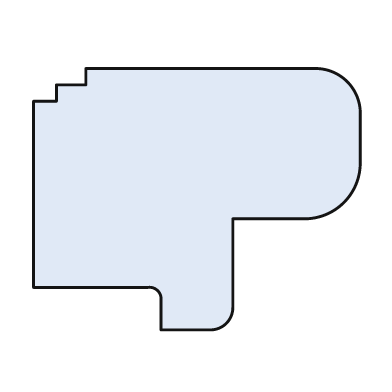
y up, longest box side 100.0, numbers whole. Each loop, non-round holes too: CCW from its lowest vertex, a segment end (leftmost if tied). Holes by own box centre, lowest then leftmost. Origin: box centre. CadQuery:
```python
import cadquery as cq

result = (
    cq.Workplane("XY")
    .moveTo(-11.0, -40.0)
    .lineTo(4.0, -40.0)
    .threePointArc((9.0, -38.0), (11.0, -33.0))
    .lineTo(11.0, -6.0)
    .lineTo(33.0, -6.0)
    .threePointArc((45.0, -1.0), (50.0, 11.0))
    .lineTo(50.0, 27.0)
    .threePointArc((46.0, 36.0), (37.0, 40.0))
    .lineTo(-34.0, 40.0)
    .lineTo(-34.0, 35.0)
    .lineTo(-43.0, 35.0)
    .lineTo(-43.0, 30.0)
    .lineTo(-50.0, 30.0)
    .lineTo(-50.0, -27.0)
    .lineTo(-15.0, -27.0)
    .threePointArc((-12.0, -28.0), (-11.0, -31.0))
    .close()
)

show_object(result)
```